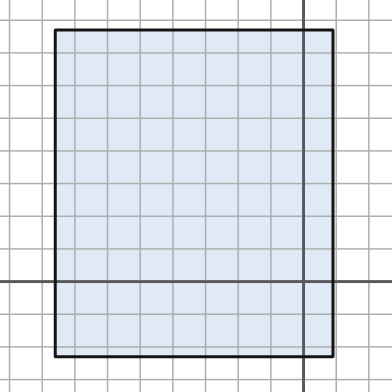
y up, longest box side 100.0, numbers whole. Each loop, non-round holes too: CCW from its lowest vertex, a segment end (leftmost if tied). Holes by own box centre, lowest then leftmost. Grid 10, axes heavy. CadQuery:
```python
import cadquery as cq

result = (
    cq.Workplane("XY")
    .moveTo(-76.0, -23.0)
    .lineTo(9.0, -23.0)
    .lineTo(9.0, 77.0)
    .lineTo(-76.0, 77.0)
    .close()
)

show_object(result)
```